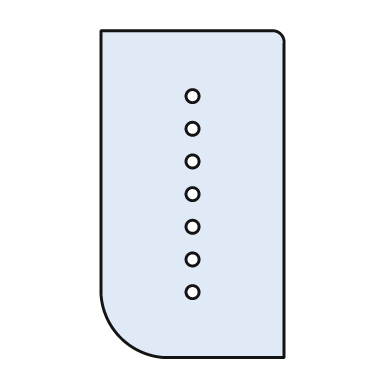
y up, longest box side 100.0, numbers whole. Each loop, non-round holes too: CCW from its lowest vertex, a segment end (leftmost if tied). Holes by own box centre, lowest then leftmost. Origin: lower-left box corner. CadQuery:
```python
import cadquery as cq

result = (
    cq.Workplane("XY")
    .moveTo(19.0, 0.0)
    .lineTo(56.0, 0.0)
    .lineTo(56.0, 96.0)
    .threePointArc((55.0, 99.0), (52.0, 100.0))
    .lineTo(0.0, 100.0)
    .lineTo(0.0, 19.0)
    .threePointArc((6.0, 6.0), (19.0, 0.0))
    .close()
    .moveTo(28.0, 20.0)
    .circle(2.0)
    .moveTo(28.0, 30.0)
    .circle(2.0)
    .moveTo(28.0, 40.0)
    .circle(2.0)
    .moveTo(28.0, 50.0)
    .circle(2.0)
    .moveTo(28.0, 60.0)
    .circle(2.0)
    .moveTo(28.0, 70.0)
    .circle(2.0)
    .moveTo(28.0, 80.0)
    .circle(2.0)
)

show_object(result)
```